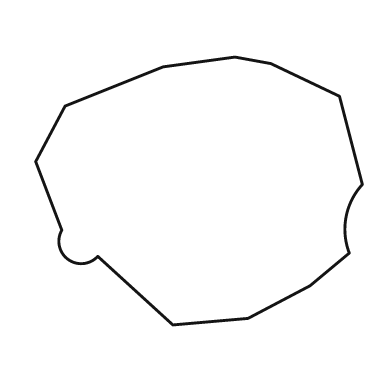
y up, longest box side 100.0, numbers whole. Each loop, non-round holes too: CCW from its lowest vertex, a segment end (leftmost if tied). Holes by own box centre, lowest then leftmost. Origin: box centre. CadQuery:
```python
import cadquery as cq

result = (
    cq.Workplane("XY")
    .moveTo(-8.0, -41.0)
    .lineTo(15.0, -39.0)
    .lineTo(34.0, -29.0)
    .lineTo(46.0, -19.0)
    .threePointArc((45.0, -8.0), (50.0, 2.0))
    .lineTo(43.0, 29.0)
    .lineTo(22.0, 39.0)
    .lineTo(11.0, 41.0)
    .lineTo(-11.0, 38.0)
    .lineTo(-41.0, 26.0)
    .lineTo(-50.0, 9.0)
    .lineTo(-42.0, -12.0)
    .threePointArc((-40.0, -21.0), (-31.0, -20.0))
    .close()
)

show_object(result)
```